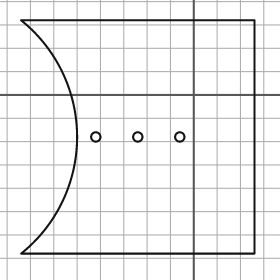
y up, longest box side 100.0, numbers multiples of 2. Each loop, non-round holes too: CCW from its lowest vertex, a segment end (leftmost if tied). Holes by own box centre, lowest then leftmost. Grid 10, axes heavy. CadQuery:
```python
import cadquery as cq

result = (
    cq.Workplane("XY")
    .moveTo(-74.0, -68.0)
    .lineTo(26.0, -68.0)
    .lineTo(26.0, 32.0)
    .lineTo(-74.0, 32.0)
    .threePointArc((-50.0, -18.0), (-74.0, -68.0))
    .close()
    .moveTo(-42.0, -18.0)
    .circle(2.0)
    .moveTo(-24.0, -18.0)
    .circle(2.0)
    .moveTo(-6.0, -18.0)
    .circle(2.0)
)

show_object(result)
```